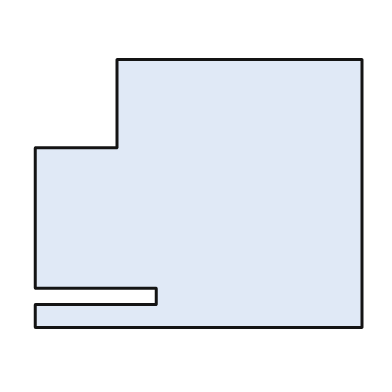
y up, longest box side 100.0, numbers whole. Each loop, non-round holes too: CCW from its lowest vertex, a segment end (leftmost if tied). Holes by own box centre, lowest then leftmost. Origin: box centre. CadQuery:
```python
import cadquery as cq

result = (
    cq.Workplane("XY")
    .moveTo(-50.0, -41.0)
    .lineTo(50.0, -41.0)
    .lineTo(50.0, 41.0)
    .lineTo(-25.0, 41.0)
    .lineTo(-25.0, 14.0)
    .lineTo(-50.0, 14.0)
    .lineTo(-50.0, -29.0)
    .lineTo(-13.0, -29.0)
    .lineTo(-13.0, -34.0)
    .lineTo(-50.0, -34.0)
    .close()
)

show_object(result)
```